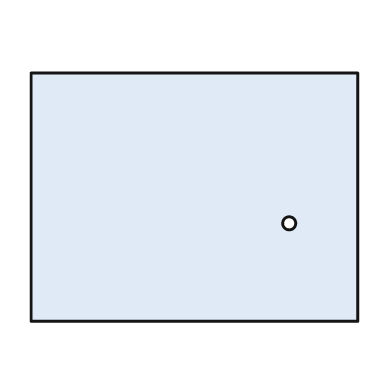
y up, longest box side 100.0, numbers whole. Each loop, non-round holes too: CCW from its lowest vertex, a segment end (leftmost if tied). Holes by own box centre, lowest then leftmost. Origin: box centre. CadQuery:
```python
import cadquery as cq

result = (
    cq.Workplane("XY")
    .moveTo(-50.0, -38.0)
    .lineTo(50.0, -38.0)
    .lineTo(50.0, 38.0)
    .lineTo(-50.0, 38.0)
    .close()
    .moveTo(29.0, -8.0)
    .circle(2.0)
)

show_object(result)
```